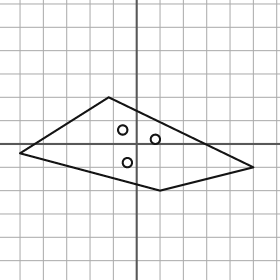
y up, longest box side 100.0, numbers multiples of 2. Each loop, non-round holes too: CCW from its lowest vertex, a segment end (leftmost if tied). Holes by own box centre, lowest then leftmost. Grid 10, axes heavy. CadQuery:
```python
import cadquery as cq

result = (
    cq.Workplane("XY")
    .moveTo(10.0, -20.0)
    .lineTo(50.0, -10.0)
    .lineTo(-12.0, 20.0)
    .lineTo(-50.0, -4.0)
    .close()
    .moveTo(-4.0, -8.0)
    .circle(2.0)
    .moveTo(8.0, 2.0)
    .circle(2.0)
    .moveTo(-6.0, 6.0)
    .circle(2.0)
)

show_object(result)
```